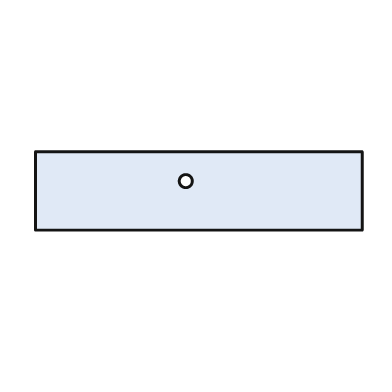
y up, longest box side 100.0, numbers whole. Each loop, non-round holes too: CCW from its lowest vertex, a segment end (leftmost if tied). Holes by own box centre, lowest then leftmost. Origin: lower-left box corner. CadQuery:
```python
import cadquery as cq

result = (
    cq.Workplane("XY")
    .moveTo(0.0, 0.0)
    .lineTo(100.0, 0.0)
    .lineTo(100.0, 24.0)
    .lineTo(0.0, 24.0)
    .close()
    .moveTo(46.0, 15.0)
    .circle(2.0)
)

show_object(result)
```